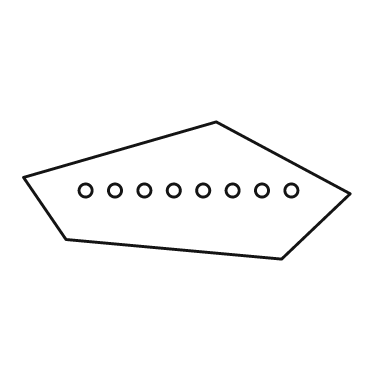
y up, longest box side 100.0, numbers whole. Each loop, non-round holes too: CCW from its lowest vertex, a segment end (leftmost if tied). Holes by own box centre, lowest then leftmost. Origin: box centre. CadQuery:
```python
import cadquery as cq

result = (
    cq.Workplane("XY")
    .moveTo(29.0, -21.0)
    .lineTo(50.0, -1.0)
    .lineTo(9.0, 21.0)
    .lineTo(-50.0, 4.0)
    .lineTo(-37.0, -15.0)
    .close()
    .moveTo(-31.0, 0.0)
    .circle(2.0)
    .moveTo(-22.0, 0.0)
    .circle(2.0)
    .moveTo(-13.0, 0.0)
    .circle(2.0)
    .moveTo(-4.0, 0.0)
    .circle(2.0)
    .moveTo(5.0, 0.0)
    .circle(2.0)
    .moveTo(14.0, 0.0)
    .circle(2.0)
    .moveTo(23.0, 0.0)
    .circle(2.0)
    .moveTo(32.0, 0.0)
    .circle(2.0)
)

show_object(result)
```